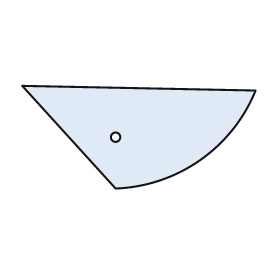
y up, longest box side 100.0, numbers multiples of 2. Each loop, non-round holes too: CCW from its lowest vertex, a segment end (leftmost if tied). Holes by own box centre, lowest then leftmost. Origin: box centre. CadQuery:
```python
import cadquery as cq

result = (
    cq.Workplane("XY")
    .moveTo(-10.0, -22.0)
    .threePointArc((26.0, -10.0), (50.0, 20.0))
    .lineTo(-50.0, 22.0)
    .close()
    .moveTo(-10.0, 0.0)
    .circle(2.0)
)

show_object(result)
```